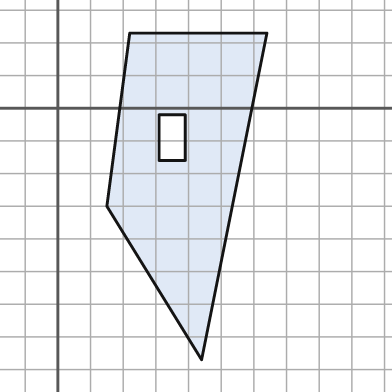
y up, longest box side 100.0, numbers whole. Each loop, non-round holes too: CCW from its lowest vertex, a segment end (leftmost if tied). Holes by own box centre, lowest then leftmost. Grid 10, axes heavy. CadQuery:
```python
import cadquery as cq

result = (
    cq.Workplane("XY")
    .moveTo(44.0, -77.0)
    .lineTo(64.0, 23.0)
    .lineTo(22.0, 23.0)
    .lineTo(15.0, -30.0)
    .close()
    .moveTo(31.0, -16.0)
    .lineTo(39.0, -16.0)
    .lineTo(39.0, -2.0)
    .lineTo(31.0, -2.0)
    .close()
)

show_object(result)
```